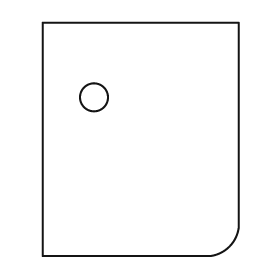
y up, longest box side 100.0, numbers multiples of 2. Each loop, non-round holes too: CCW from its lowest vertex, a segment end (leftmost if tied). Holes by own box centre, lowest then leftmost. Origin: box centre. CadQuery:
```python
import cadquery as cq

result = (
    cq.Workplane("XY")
    .moveTo(-42.0, -50.0)
    .lineTo(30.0, -50.0)
    .threePointArc((38.0, -46.0), (42.0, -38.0))
    .lineTo(42.0, 50.0)
    .lineTo(-42.0, 50.0)
    .close()
    .moveTo(-20.0, 18.0)
    .circle(6.0)
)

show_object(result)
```